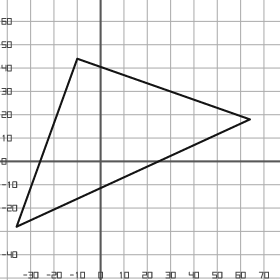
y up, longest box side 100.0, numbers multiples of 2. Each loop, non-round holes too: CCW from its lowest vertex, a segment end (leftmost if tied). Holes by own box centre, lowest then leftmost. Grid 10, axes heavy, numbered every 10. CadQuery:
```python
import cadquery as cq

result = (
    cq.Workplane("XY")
    .moveTo(-36.0, -28.0)
    .lineTo(64.0, 18.0)
    .lineTo(-10.0, 44.0)
    .close()
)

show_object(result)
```